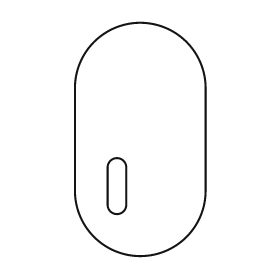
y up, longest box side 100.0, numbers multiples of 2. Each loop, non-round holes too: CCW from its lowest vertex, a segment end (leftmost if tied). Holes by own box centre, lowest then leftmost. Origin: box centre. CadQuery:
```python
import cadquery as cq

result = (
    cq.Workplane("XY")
    .moveTo(-28.0, -22.0)
    .threePointArc((0.0, -50.0), (28.0, -22.0))
    .lineTo(28.0, 22.0)
    .threePointArc((0.0, 50.0), (-28.0, 22.0))
    .close()
    .moveTo(-14.0, -28.0)
    .threePointArc((-10.0, -32.0), (-6.0, -28.0))
    .lineTo(-6.0, -12.0)
    .threePointArc((-10.0, -8.0), (-14.0, -12.0))
    .close()
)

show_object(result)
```